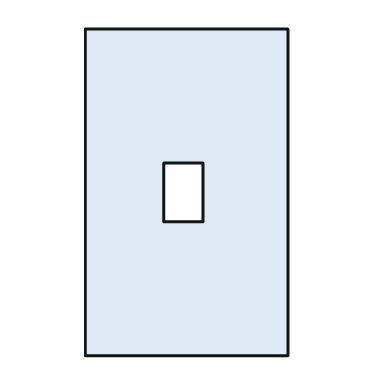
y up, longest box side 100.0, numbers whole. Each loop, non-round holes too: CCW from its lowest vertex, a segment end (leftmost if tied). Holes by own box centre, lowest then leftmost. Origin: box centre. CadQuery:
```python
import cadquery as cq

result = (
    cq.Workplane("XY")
    .moveTo(-31.0, -50.0)
    .lineTo(31.0, -50.0)
    .lineTo(31.0, 50.0)
    .lineTo(-31.0, 50.0)
    .close()
    .moveTo(-7.0, -9.0)
    .lineTo(5.0, -9.0)
    .lineTo(5.0, 9.0)
    .lineTo(-7.0, 9.0)
    .close()
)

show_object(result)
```